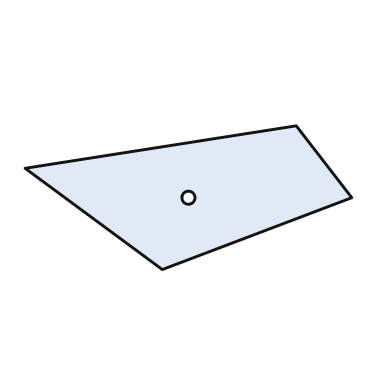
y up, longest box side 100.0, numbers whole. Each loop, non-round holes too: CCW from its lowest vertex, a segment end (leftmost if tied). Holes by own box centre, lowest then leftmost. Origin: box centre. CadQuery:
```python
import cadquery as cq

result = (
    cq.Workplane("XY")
    .moveTo(-8.0, -22.0)
    .lineTo(50.0, 0.0)
    .lineTo(33.0, 22.0)
    .lineTo(-50.0, 9.0)
    .close()
    .moveTo(0.0, 0.0)
    .circle(2.0)
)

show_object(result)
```